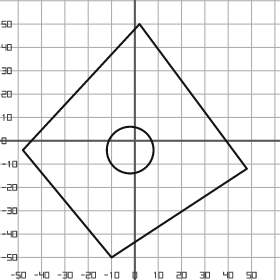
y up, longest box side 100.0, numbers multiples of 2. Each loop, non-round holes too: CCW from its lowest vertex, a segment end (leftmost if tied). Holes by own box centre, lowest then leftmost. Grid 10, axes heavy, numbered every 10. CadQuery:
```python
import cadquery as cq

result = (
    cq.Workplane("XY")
    .moveTo(-10.0, -50.0)
    .lineTo(48.0, -12.0)
    .lineTo(2.0, 50.0)
    .lineTo(-48.0, -4.0)
    .close()
    .moveTo(-2.0, -4.0)
    .circle(10.0)
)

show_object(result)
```